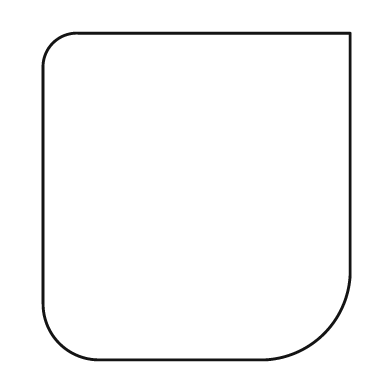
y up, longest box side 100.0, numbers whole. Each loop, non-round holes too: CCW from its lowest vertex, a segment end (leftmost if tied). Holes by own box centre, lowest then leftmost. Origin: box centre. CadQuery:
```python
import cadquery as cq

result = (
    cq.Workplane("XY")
    .moveTo(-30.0, -50.0)
    .lineTo(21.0, -50.0)
    .threePointArc((39.0, -42.0), (47.0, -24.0))
    .lineTo(47.0, 50.0)
    .lineTo(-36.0, 50.0)
    .threePointArc((-44.0, 47.0), (-47.0, 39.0))
    .lineTo(-47.0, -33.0)
    .threePointArc((-42.0, -45.0), (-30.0, -50.0))
    .close()
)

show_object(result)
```